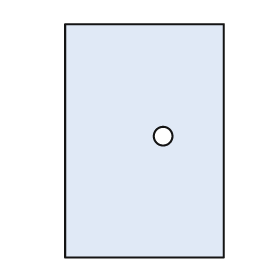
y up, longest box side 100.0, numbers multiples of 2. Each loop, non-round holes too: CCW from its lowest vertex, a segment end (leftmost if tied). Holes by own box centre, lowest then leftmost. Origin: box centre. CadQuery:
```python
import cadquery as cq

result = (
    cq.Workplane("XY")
    .moveTo(-34.0, -50.0)
    .lineTo(34.0, -50.0)
    .lineTo(34.0, 50.0)
    .lineTo(-34.0, 50.0)
    .close()
    .moveTo(8.0, 2.0)
    .circle(4.0)
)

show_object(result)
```